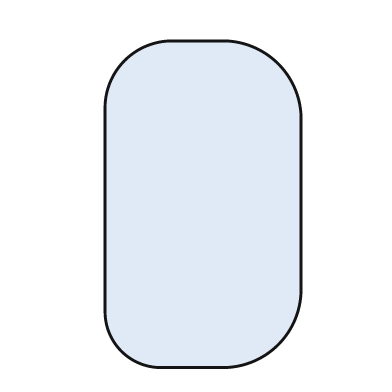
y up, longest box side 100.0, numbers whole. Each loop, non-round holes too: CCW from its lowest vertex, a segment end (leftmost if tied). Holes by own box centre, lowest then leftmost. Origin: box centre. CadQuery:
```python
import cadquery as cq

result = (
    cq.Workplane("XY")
    .moveTo(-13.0, -50.0)
    .lineTo(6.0, -50.0)
    .threePointArc((23.0, -43.0), (30.0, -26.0))
    .lineTo(30.0, 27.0)
    .threePointArc((23.0, 43.0), (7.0, 50.0))
    .lineTo(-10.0, 50.0)
    .threePointArc((-24.0, 44.0), (-30.0, 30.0))
    .lineTo(-30.0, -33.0)
    .threePointArc((-25.0, -45.0), (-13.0, -50.0))
    .close()
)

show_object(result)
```